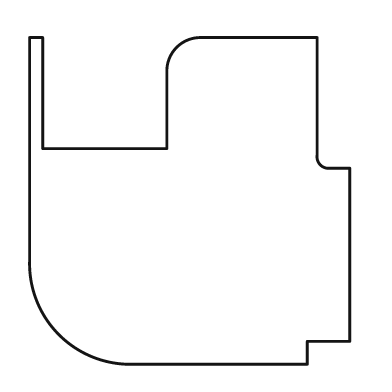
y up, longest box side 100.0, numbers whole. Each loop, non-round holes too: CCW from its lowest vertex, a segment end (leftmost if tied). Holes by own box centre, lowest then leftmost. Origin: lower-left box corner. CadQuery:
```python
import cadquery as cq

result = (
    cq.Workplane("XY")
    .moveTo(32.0, 0.0)
    .lineTo(85.0, 0.0)
    .lineTo(85.0, 7.0)
    .lineTo(98.0, 7.0)
    .lineTo(98.0, 60.0)
    .lineTo(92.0, 60.0)
    .threePointArc((89.0, 61.0), (88.0, 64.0))
    .lineTo(88.0, 100.0)
    .lineTo(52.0, 100.0)
    .threePointArc((45.0, 97.0), (42.0, 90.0))
    .lineTo(42.0, 66.0)
    .lineTo(4.0, 66.0)
    .lineTo(4.0, 100.0)
    .lineTo(0.0, 100.0)
    .lineTo(0.0, 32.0)
    .threePointArc((9.0, 9.0), (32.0, 0.0))
    .close()
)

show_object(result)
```